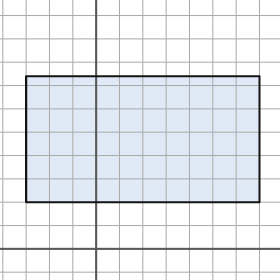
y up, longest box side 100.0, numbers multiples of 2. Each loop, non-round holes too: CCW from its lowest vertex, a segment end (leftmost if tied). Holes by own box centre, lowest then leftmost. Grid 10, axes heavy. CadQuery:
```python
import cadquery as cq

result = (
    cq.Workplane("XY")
    .moveTo(-30.0, 20.0)
    .lineTo(70.0, 20.0)
    .lineTo(70.0, 74.0)
    .lineTo(-30.0, 74.0)
    .close()
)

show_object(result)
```